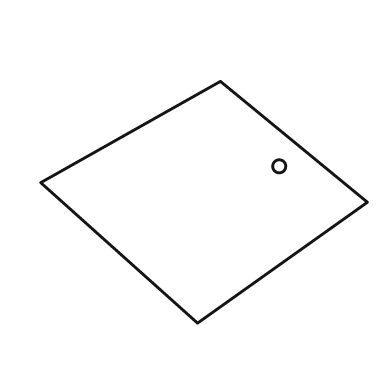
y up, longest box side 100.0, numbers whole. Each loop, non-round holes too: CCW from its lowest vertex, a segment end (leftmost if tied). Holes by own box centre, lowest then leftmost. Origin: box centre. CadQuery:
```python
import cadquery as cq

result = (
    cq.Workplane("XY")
    .moveTo(-2.0, -37.0)
    .lineTo(50.0, 0.0)
    .lineTo(5.0, 37.0)
    .lineTo(-50.0, 6.0)
    .close()
    .moveTo(23.0, 11.0)
    .circle(2.0)
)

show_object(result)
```